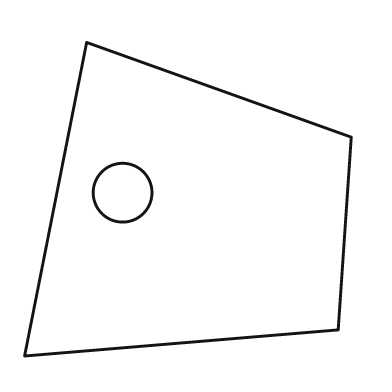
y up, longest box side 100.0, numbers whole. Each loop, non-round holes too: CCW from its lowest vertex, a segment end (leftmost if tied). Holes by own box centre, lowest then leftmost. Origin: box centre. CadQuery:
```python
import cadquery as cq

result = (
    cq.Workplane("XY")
    .moveTo(-50.0, -48.0)
    .lineTo(46.0, -40.0)
    .lineTo(50.0, 19.0)
    .lineTo(-31.0, 48.0)
    .close()
    .moveTo(-20.0, 2.0)
    .circle(9.0)
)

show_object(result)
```